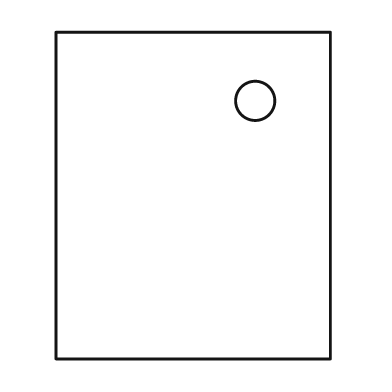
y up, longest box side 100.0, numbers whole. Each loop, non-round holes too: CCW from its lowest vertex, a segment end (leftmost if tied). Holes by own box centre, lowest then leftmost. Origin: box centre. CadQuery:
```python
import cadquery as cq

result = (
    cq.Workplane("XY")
    .moveTo(-42.0, -50.0)
    .lineTo(42.0, -50.0)
    .lineTo(42.0, 50.0)
    .lineTo(-42.0, 50.0)
    .close()
    .moveTo(19.0, 29.0)
    .circle(6.0)
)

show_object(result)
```